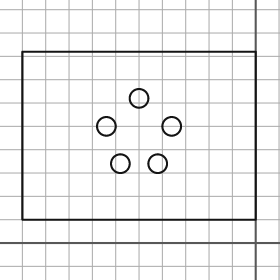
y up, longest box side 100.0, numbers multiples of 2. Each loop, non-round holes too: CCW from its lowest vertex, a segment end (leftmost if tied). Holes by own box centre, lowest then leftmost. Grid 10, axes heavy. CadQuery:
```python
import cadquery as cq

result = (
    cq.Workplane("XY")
    .moveTo(-100.0, 10.0)
    .lineTo(0.0, 10.0)
    .lineTo(0.0, 82.0)
    .lineTo(-100.0, 82.0)
    .close()
    .moveTo(-58.0, 34.0)
    .circle(4.0)
    .moveTo(-42.0, 34.0)
    .circle(4.0)
    .moveTo(-64.0, 50.0)
    .circle(4.0)
    .moveTo(-36.0, 50.0)
    .circle(4.0)
    .moveTo(-50.0, 62.0)
    .circle(4.0)
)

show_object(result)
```